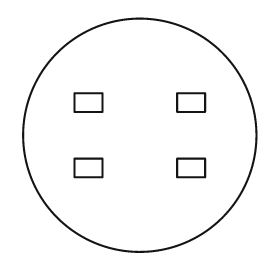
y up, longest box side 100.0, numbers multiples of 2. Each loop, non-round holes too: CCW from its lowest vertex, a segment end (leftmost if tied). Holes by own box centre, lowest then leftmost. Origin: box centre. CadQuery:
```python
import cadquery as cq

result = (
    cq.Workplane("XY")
    .moveTo(0.0, 0.0)
    .circle(50.0)
    .moveTo(-28.0, -18.0)
    .lineTo(-16.0, -18.0)
    .lineTo(-16.0, -10.0)
    .lineTo(-28.0, -10.0)
    .close()
    .moveTo(16.0, -18.0)
    .lineTo(28.0, -18.0)
    .lineTo(28.0, -10.0)
    .lineTo(16.0, -10.0)
    .close()
    .moveTo(-28.0, 10.0)
    .lineTo(-16.0, 10.0)
    .lineTo(-16.0, 18.0)
    .lineTo(-28.0, 18.0)
    .close()
    .moveTo(16.0, 10.0)
    .lineTo(28.0, 10.0)
    .lineTo(28.0, 18.0)
    .lineTo(16.0, 18.0)
    .close()
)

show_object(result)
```